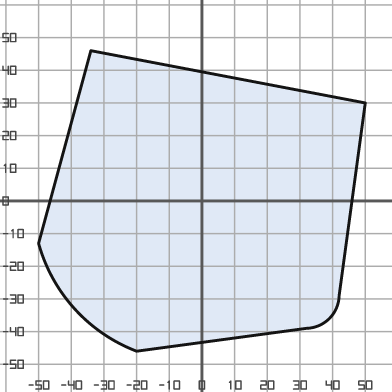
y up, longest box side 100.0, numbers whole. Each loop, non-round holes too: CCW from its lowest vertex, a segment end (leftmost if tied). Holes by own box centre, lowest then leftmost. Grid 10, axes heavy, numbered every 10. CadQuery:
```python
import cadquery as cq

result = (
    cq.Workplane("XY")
    .moveTo(-20.0, -46.0)
    .lineTo(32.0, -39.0)
    .threePointArc((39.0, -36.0), (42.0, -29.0))
    .lineTo(50.0, 30.0)
    .lineTo(-34.0, 46.0)
    .lineTo(-50.0, -13.0)
    .threePointArc((-39.0, -33.0), (-20.0, -46.0))
    .close()
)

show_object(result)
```